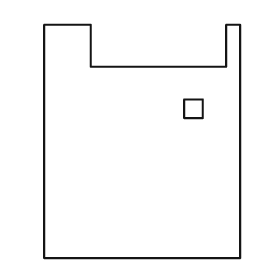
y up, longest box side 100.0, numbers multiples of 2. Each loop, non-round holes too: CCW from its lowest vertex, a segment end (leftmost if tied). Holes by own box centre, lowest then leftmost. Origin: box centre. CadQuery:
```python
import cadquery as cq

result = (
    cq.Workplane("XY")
    .moveTo(-42.0, -50.0)
    .lineTo(42.0, -50.0)
    .lineTo(42.0, 50.0)
    .lineTo(36.0, 50.0)
    .lineTo(36.0, 32.0)
    .lineTo(-22.0, 32.0)
    .lineTo(-22.0, 50.0)
    .lineTo(-42.0, 50.0)
    .close()
    .moveTo(18.0, 10.0)
    .lineTo(26.0, 10.0)
    .lineTo(26.0, 18.0)
    .lineTo(18.0, 18.0)
    .close()
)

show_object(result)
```